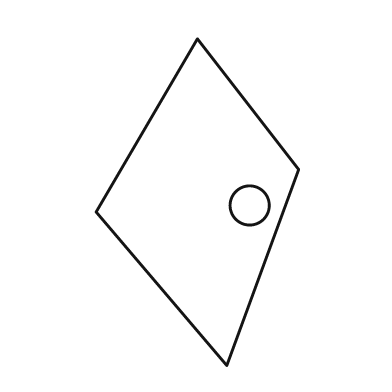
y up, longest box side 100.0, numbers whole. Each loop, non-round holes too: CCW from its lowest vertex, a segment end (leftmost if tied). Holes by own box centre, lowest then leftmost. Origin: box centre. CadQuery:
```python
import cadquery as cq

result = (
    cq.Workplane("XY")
    .moveTo(9.0, -50.0)
    .lineTo(31.0, 10.0)
    .lineTo(0.0, 50.0)
    .lineTo(-31.0, -3.0)
    .close()
    .moveTo(16.0, -1.0)
    .circle(6.0)
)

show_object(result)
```